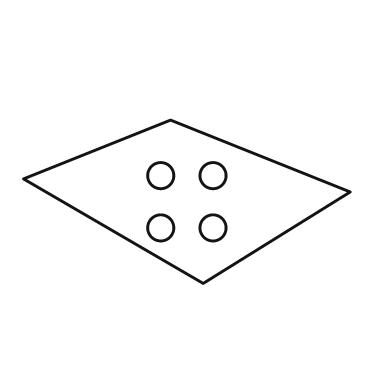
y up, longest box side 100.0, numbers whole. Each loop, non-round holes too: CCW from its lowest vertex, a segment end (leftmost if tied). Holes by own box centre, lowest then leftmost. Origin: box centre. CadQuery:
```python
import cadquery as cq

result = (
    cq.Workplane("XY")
    .moveTo(5.0, -25.0)
    .lineTo(50.0, 3.0)
    .lineTo(-5.0, 25.0)
    .lineTo(-50.0, 7.0)
    .close()
    .moveTo(-8.0, -8.0)
    .circle(4.0)
    .moveTo(8.0, -8.0)
    .circle(4.0)
    .moveTo(-8.0, 8.0)
    .circle(4.0)
    .moveTo(8.0, 8.0)
    .circle(4.0)
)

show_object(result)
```